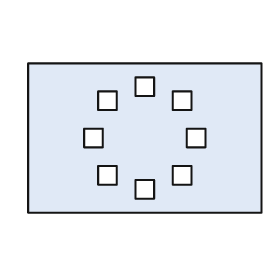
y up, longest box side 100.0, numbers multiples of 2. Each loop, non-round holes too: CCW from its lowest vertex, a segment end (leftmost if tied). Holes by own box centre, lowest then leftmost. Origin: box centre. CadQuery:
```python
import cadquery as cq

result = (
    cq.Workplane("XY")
    .moveTo(-50.0, -32.0)
    .lineTo(50.0, -32.0)
    .lineTo(50.0, 32.0)
    .lineTo(-50.0, 32.0)
    .close()
    .moveTo(-4.0, -26.0)
    .lineTo(4.0, -26.0)
    .lineTo(4.0, -18.0)
    .lineTo(-4.0, -18.0)
    .close()
    .moveTo(-20.0, -20.0)
    .lineTo(-12.0, -20.0)
    .lineTo(-12.0, -12.0)
    .lineTo(-20.0, -12.0)
    .close()
    .moveTo(12.0, -20.0)
    .lineTo(20.0, -20.0)
    .lineTo(20.0, -12.0)
    .lineTo(12.0, -12.0)
    .close()
    .moveTo(-26.0, -4.0)
    .lineTo(-18.0, -4.0)
    .lineTo(-18.0, 4.0)
    .lineTo(-26.0, 4.0)
    .close()
    .moveTo(18.0, -4.0)
    .lineTo(26.0, -4.0)
    .lineTo(26.0, 4.0)
    .lineTo(18.0, 4.0)
    .close()
    .moveTo(-20.0, 12.0)
    .lineTo(-12.0, 12.0)
    .lineTo(-12.0, 20.0)
    .lineTo(-20.0, 20.0)
    .close()
    .moveTo(12.0, 12.0)
    .lineTo(20.0, 12.0)
    .lineTo(20.0, 20.0)
    .lineTo(12.0, 20.0)
    .close()
    .moveTo(-4.0, 18.0)
    .lineTo(4.0, 18.0)
    .lineTo(4.0, 26.0)
    .lineTo(-4.0, 26.0)
    .close()
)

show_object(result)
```